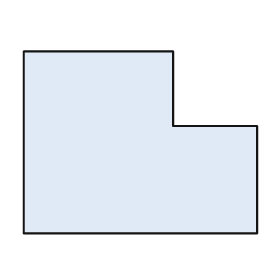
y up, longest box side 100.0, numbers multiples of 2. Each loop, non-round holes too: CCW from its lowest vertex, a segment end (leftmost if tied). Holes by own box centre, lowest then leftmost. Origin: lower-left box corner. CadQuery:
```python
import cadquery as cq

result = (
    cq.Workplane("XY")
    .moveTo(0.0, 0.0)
    .lineTo(100.0, 0.0)
    .lineTo(100.0, 46.0)
    .lineTo(64.0, 46.0)
    .lineTo(64.0, 78.0)
    .lineTo(0.0, 78.0)
    .close()
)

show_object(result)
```